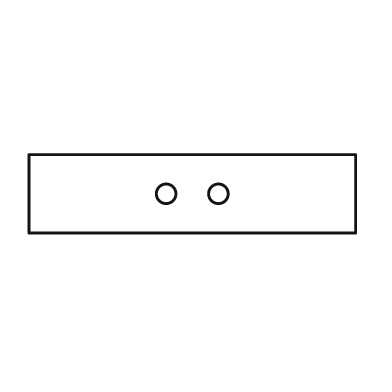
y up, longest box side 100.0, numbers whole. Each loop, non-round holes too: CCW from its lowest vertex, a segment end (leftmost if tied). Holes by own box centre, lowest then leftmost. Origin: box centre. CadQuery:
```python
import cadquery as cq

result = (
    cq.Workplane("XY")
    .moveTo(-50.0, -12.0)
    .lineTo(50.0, -12.0)
    .lineTo(50.0, 12.0)
    .lineTo(-50.0, 12.0)
    .close()
    .moveTo(-8.0, 0.0)
    .circle(3.0)
    .moveTo(8.0, 0.0)
    .circle(3.0)
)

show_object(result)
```